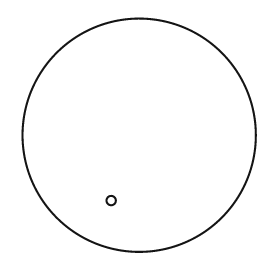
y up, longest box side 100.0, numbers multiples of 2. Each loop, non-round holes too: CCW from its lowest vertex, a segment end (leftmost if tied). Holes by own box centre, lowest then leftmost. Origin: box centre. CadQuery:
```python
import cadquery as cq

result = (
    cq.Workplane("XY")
    .moveTo(0.0, 0.0)
    .circle(50.0)
    .moveTo(-12.0, -28.0)
    .circle(2.0)
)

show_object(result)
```